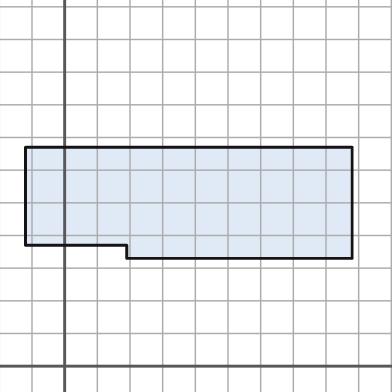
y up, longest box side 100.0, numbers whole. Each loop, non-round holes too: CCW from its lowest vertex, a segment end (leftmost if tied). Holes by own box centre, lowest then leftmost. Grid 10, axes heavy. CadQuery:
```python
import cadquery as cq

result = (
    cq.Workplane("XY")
    .moveTo(19.0, 33.0)
    .lineTo(88.0, 33.0)
    .lineTo(88.0, 67.0)
    .lineTo(-12.0, 67.0)
    .lineTo(-12.0, 37.0)
    .lineTo(19.0, 37.0)
    .close()
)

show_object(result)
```